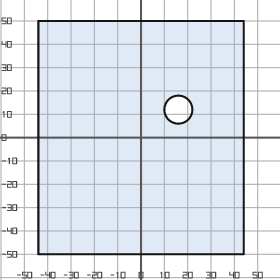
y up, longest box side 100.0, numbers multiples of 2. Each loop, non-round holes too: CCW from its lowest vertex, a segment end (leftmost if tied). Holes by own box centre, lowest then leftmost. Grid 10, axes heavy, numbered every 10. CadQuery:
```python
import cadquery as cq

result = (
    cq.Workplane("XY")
    .moveTo(-44.0, -50.0)
    .lineTo(44.0, -50.0)
    .lineTo(44.0, 50.0)
    .lineTo(-44.0, 50.0)
    .close()
    .moveTo(16.0, 12.0)
    .circle(6.0)
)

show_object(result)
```